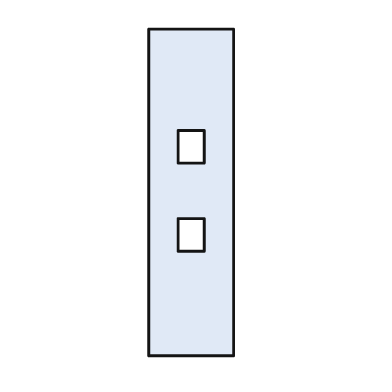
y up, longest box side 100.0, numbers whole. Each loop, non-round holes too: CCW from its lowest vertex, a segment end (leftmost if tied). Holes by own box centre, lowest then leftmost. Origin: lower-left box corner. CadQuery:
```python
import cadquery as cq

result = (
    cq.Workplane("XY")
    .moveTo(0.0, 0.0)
    .lineTo(26.0, 0.0)
    .lineTo(26.0, 100.0)
    .lineTo(0.0, 100.0)
    .close()
    .moveTo(9.0, 32.0)
    .lineTo(17.0, 32.0)
    .lineTo(17.0, 42.0)
    .lineTo(9.0, 42.0)
    .close()
    .moveTo(9.0, 59.0)
    .lineTo(17.0, 59.0)
    .lineTo(17.0, 69.0)
    .lineTo(9.0, 69.0)
    .close()
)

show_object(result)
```